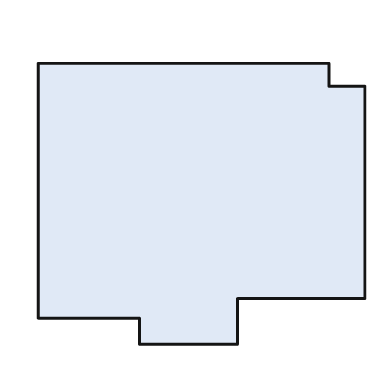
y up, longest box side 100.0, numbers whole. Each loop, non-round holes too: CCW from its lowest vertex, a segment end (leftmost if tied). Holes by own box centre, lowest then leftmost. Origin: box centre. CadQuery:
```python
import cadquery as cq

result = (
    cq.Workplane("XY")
    .moveTo(-19.0, -43.0)
    .lineTo(11.0, -43.0)
    .lineTo(11.0, -29.0)
    .lineTo(50.0, -29.0)
    .lineTo(50.0, 36.0)
    .lineTo(39.0, 36.0)
    .lineTo(39.0, 43.0)
    .lineTo(-50.0, 43.0)
    .lineTo(-50.0, -35.0)
    .lineTo(-19.0, -35.0)
    .close()
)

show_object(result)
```